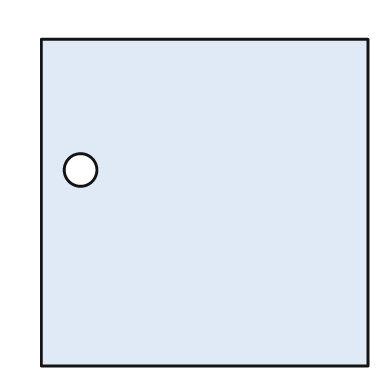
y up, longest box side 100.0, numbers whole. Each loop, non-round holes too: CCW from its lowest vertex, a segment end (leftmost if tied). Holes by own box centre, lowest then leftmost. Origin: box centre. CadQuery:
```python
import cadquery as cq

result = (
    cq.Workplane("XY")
    .moveTo(-50.0, -50.0)
    .lineTo(50.0, -50.0)
    .lineTo(50.0, 50.0)
    .lineTo(-50.0, 50.0)
    .close()
    .moveTo(-38.0, 10.0)
    .circle(5.0)
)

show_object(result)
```